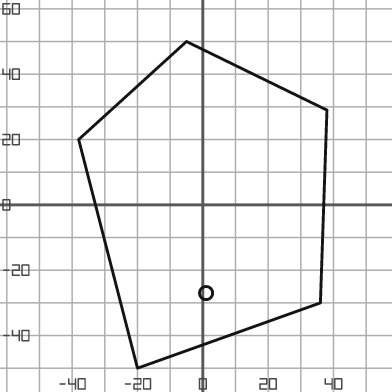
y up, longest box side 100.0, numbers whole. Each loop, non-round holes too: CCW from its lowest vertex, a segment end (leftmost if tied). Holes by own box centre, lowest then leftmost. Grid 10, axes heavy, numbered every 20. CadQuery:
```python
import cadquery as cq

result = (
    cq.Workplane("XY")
    .moveTo(-20.0, -50.0)
    .lineTo(36.0, -30.0)
    .lineTo(38.0, 29.0)
    .lineTo(-5.0, 50.0)
    .lineTo(-38.0, 20.0)
    .close()
    .moveTo(1.0, -27.0)
    .circle(2.0)
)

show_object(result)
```